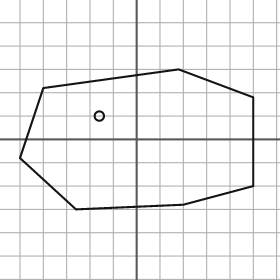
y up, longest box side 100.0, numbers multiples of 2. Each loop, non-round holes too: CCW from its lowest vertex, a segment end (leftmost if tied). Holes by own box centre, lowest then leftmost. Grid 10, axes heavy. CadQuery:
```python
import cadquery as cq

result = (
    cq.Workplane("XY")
    .moveTo(-26.0, -30.0)
    .lineTo(20.0, -28.0)
    .lineTo(50.0, -20.0)
    .lineTo(50.0, 18.0)
    .lineTo(18.0, 30.0)
    .lineTo(-40.0, 22.0)
    .lineTo(-50.0, -8.0)
    .close()
    .moveTo(-16.0, 10.0)
    .circle(2.0)
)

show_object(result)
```